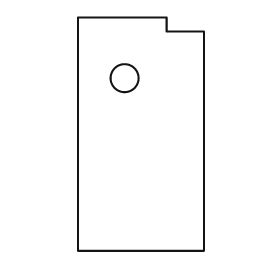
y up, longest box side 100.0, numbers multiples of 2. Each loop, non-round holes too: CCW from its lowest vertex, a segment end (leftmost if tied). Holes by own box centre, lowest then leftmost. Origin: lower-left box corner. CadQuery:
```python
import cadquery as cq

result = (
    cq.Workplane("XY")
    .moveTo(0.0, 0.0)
    .lineTo(54.0, 0.0)
    .lineTo(54.0, 94.0)
    .lineTo(38.0, 94.0)
    .lineTo(38.0, 100.0)
    .lineTo(0.0, 100.0)
    .close()
    .moveTo(20.0, 74.0)
    .circle(6.0)
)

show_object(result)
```